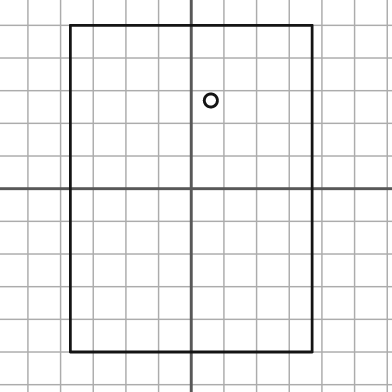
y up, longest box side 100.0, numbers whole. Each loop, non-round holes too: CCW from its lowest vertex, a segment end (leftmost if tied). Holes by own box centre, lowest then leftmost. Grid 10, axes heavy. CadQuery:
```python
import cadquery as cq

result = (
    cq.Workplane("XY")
    .moveTo(-37.0, -50.0)
    .lineTo(37.0, -50.0)
    .lineTo(37.0, 50.0)
    .lineTo(-37.0, 50.0)
    .close()
    .moveTo(6.0, 27.0)
    .circle(2.0)
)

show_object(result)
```